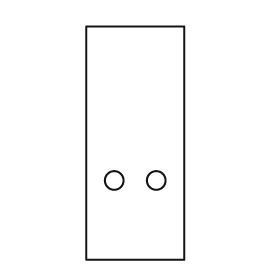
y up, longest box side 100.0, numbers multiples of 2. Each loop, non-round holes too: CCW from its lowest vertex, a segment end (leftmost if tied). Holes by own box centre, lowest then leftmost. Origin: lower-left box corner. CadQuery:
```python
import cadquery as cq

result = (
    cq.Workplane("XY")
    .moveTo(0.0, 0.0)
    .lineTo(42.0, 0.0)
    .lineTo(42.0, 100.0)
    .lineTo(0.0, 100.0)
    .close()
    .moveTo(12.0, 34.0)
    .circle(4.0)
    .moveTo(30.0, 34.0)
    .circle(4.0)
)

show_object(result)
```